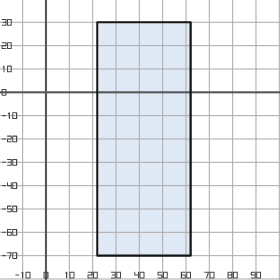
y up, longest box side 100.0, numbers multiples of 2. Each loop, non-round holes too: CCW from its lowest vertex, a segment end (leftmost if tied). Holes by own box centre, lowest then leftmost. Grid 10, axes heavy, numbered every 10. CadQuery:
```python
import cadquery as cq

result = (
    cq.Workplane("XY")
    .moveTo(22.0, -70.0)
    .lineTo(62.0, -70.0)
    .lineTo(62.0, 30.0)
    .lineTo(22.0, 30.0)
    .close()
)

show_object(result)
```